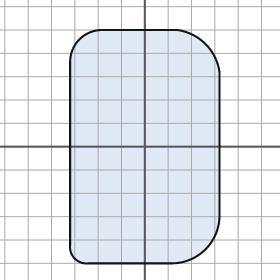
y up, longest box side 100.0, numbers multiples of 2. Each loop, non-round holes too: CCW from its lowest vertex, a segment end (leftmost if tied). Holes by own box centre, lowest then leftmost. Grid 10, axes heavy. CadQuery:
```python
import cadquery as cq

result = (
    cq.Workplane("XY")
    .moveTo(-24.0, -50.0)
    .lineTo(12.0, -50.0)
    .threePointArc((26.0, -44.0), (32.0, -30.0))
    .lineTo(32.0, 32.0)
    .threePointArc((26.0, 44.0), (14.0, 50.0))
    .lineTo(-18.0, 50.0)
    .threePointArc((-28.0, 46.0), (-32.0, 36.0))
    .lineTo(-32.0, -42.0)
    .threePointArc((-30.0, -48.0), (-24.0, -50.0))
    .close()
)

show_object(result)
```